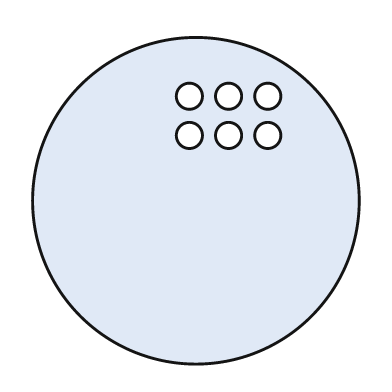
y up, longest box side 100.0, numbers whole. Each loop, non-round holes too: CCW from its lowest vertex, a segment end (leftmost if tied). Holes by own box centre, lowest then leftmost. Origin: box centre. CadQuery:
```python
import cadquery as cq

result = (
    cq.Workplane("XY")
    .moveTo(0.0, 0.0)
    .circle(50.0)
    .moveTo(-2.0, 20.0)
    .circle(4.0)
    .moveTo(10.0, 20.0)
    .circle(4.0)
    .moveTo(22.0, 20.0)
    .circle(4.0)
    .moveTo(-2.0, 32.0)
    .circle(4.0)
    .moveTo(10.0, 32.0)
    .circle(4.0)
    .moveTo(22.0, 32.0)
    .circle(4.0)
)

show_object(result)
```